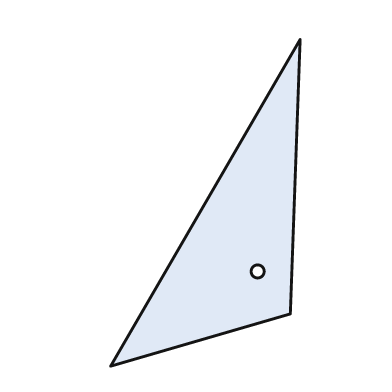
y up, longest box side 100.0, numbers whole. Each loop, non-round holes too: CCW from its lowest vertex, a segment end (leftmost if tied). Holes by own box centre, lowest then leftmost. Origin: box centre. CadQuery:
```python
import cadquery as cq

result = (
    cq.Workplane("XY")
    .moveTo(-29.0, -50.0)
    .lineTo(26.0, -34.0)
    .lineTo(29.0, 50.0)
    .close()
    .moveTo(16.0, -21.0)
    .circle(2.0)
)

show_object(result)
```